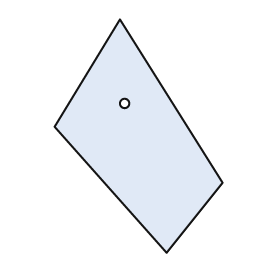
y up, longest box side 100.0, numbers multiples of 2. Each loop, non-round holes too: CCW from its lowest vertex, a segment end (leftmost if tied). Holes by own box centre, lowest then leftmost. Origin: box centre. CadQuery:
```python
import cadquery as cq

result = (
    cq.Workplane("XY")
    .moveTo(12.0, -50.0)
    .lineTo(36.0, -20.0)
    .lineTo(-8.0, 50.0)
    .lineTo(-36.0, 4.0)
    .close()
    .moveTo(-6.0, 14.0)
    .circle(2.0)
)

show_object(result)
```